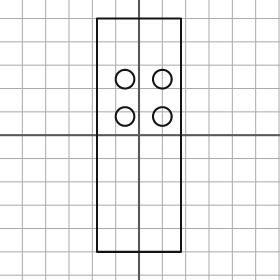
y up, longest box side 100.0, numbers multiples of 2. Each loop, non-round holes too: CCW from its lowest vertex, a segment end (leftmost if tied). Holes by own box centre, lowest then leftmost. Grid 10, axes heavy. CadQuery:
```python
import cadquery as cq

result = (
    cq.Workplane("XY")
    .moveTo(-18.0, -50.0)
    .lineTo(18.0, -50.0)
    .lineTo(18.0, 50.0)
    .lineTo(-18.0, 50.0)
    .close()
    .moveTo(-6.0, 8.0)
    .circle(4.0)
    .moveTo(10.0, 8.0)
    .circle(4.0)
    .moveTo(-6.0, 24.0)
    .circle(4.0)
    .moveTo(10.0, 24.0)
    .circle(4.0)
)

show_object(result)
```